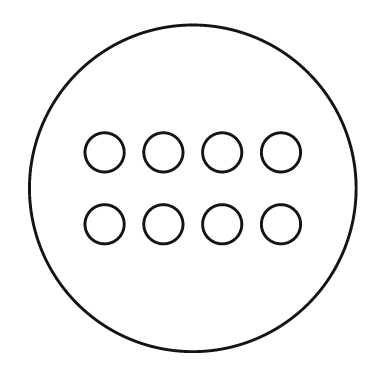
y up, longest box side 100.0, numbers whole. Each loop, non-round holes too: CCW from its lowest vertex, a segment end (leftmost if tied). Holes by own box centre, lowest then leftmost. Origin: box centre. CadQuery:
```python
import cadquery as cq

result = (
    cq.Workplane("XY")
    .moveTo(0.0, 0.0)
    .circle(50.0)
    .moveTo(-27.0, -11.0)
    .circle(6.0)
    .moveTo(-9.0, -11.0)
    .circle(6.0)
    .moveTo(9.0, -11.0)
    .circle(6.0)
    .moveTo(27.0, -11.0)
    .circle(6.0)
    .moveTo(-27.0, 11.0)
    .circle(6.0)
    .moveTo(-9.0, 11.0)
    .circle(6.0)
    .moveTo(9.0, 11.0)
    .circle(6.0)
    .moveTo(27.0, 11.0)
    .circle(6.0)
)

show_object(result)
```